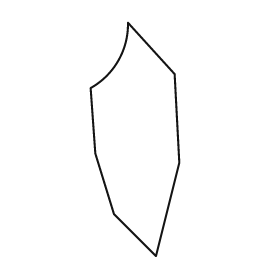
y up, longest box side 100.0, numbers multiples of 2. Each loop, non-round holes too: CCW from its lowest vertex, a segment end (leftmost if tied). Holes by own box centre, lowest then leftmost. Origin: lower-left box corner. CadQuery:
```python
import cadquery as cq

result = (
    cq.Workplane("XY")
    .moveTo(28.0, 0.0)
    .lineTo(38.0, 40.0)
    .lineTo(36.0, 78.0)
    .lineTo(16.0, 100.0)
    .threePointArc((12.0, 84.0), (0.0, 72.0))
    .lineTo(2.0, 44.0)
    .lineTo(10.0, 18.0)
    .close()
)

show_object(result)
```